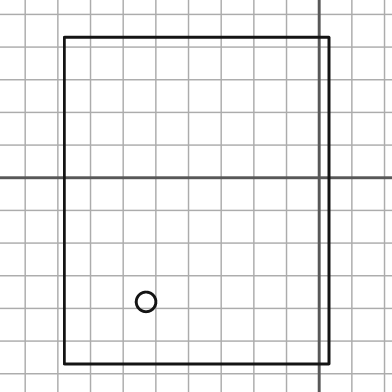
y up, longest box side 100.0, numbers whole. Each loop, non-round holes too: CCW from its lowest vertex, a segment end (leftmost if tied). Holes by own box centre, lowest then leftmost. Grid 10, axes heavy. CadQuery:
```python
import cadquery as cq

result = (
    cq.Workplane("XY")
    .moveTo(-78.0, -57.0)
    .lineTo(3.0, -57.0)
    .lineTo(3.0, 43.0)
    .lineTo(-78.0, 43.0)
    .close()
    .moveTo(-53.0, -38.0)
    .circle(3.0)
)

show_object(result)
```